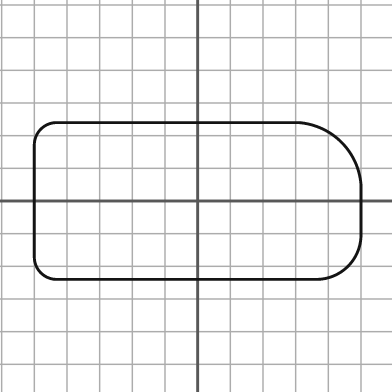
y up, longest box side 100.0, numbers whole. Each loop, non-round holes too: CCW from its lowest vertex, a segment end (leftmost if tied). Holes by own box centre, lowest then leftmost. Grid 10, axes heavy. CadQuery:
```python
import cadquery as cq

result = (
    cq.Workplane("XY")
    .moveTo(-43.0, -24.0)
    .lineTo(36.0, -24.0)
    .threePointArc((46.0, -20.0), (50.0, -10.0))
    .lineTo(50.0, 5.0)
    .threePointArc((44.0, 18.0), (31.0, 24.0))
    .lineTo(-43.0, 24.0)
    .threePointArc((-48.0, 22.0), (-50.0, 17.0))
    .lineTo(-50.0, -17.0)
    .threePointArc((-48.0, -22.0), (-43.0, -24.0))
    .close()
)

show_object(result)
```